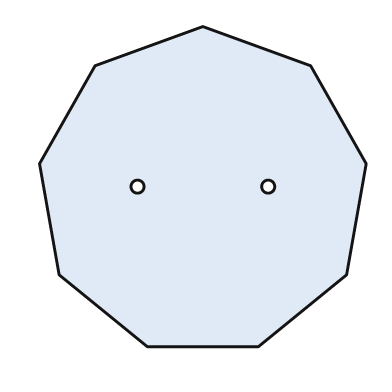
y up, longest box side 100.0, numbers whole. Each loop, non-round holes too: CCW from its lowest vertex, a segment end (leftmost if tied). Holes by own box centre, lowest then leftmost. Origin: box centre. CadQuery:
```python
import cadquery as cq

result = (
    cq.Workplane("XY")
    .moveTo(-17.0, -49.0)
    .lineTo(17.0, -49.0)
    .lineTo(44.0, -27.0)
    .lineTo(50.0, 7.0)
    .lineTo(33.0, 37.0)
    .lineTo(0.0, 49.0)
    .lineTo(-33.0, 37.0)
    .lineTo(-50.0, 7.0)
    .lineTo(-44.0, -27.0)
    .close()
    .moveTo(-20.0, 0.0)
    .circle(2.0)
    .moveTo(20.0, 0.0)
    .circle(2.0)
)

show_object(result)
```